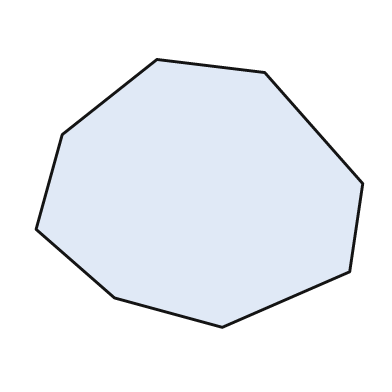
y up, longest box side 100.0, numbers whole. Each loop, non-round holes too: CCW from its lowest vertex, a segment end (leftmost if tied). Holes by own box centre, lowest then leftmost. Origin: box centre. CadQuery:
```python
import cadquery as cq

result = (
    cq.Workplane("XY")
    .moveTo(7.0, -41.0)
    .lineTo(46.0, -24.0)
    .lineTo(50.0, 3.0)
    .lineTo(20.0, 37.0)
    .lineTo(-13.0, 41.0)
    .lineTo(-42.0, 18.0)
    .lineTo(-50.0, -11.0)
    .lineTo(-26.0, -32.0)
    .close()
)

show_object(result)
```